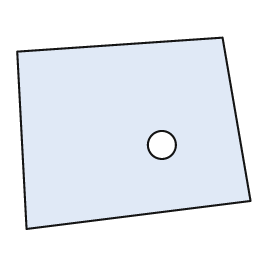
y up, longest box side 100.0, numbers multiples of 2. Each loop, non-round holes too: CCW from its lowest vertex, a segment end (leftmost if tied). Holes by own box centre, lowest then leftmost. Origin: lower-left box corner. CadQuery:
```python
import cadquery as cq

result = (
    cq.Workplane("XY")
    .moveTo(4.0, 0.0)
    .lineTo(100.0, 12.0)
    .lineTo(88.0, 82.0)
    .lineTo(0.0, 76.0)
    .close()
    .moveTo(62.0, 36.0)
    .circle(6.0)
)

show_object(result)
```